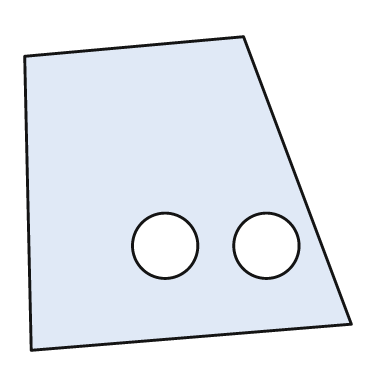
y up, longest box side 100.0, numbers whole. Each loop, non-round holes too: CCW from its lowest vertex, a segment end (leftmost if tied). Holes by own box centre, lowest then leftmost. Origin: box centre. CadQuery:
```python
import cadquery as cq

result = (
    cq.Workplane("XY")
    .moveTo(-48.0, -48.0)
    .lineTo(50.0, -40.0)
    .lineTo(17.0, 48.0)
    .lineTo(-50.0, 42.0)
    .close()
    .moveTo(-7.0, -16.0)
    .circle(10.0)
    .moveTo(24.0, -16.0)
    .circle(10.0)
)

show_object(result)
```